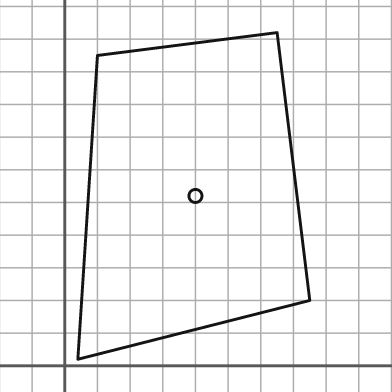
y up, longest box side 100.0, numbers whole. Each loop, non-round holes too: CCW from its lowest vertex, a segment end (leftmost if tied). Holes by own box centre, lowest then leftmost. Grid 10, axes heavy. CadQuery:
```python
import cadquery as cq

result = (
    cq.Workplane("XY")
    .moveTo(4.0, 2.0)
    .lineTo(75.0, 20.0)
    .lineTo(65.0, 102.0)
    .lineTo(10.0, 95.0)
    .close()
    .moveTo(40.0, 52.0)
    .circle(2.0)
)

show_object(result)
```